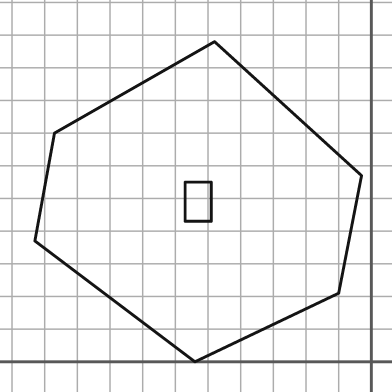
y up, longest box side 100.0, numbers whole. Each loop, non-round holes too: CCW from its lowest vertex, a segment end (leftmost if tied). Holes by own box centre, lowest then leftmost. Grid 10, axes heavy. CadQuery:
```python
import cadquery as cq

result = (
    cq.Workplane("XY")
    .moveTo(-54.0, 0.0)
    .lineTo(-10.0, 21.0)
    .lineTo(-3.0, 57.0)
    .lineTo(-48.0, 98.0)
    .lineTo(-97.0, 70.0)
    .lineTo(-103.0, 37.0)
    .close()
    .moveTo(-57.0, 43.0)
    .lineTo(-49.0, 43.0)
    .lineTo(-49.0, 55.0)
    .lineTo(-57.0, 55.0)
    .close()
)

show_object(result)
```